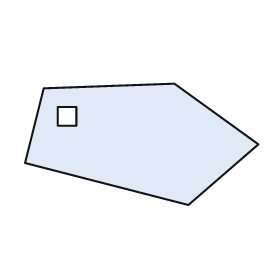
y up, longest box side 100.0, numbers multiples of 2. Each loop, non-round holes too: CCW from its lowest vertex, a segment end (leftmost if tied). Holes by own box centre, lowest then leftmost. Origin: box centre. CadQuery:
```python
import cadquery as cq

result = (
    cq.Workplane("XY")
    .moveTo(20.0, -26.0)
    .lineTo(50.0, 0.0)
    .lineTo(14.0, 26.0)
    .lineTo(-42.0, 24.0)
    .lineTo(-50.0, -8.0)
    .close()
    .moveTo(-36.0, 8.0)
    .lineTo(-28.0, 8.0)
    .lineTo(-28.0, 16.0)
    .lineTo(-36.0, 16.0)
    .close()
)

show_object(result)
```